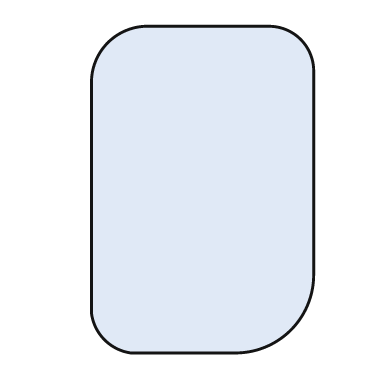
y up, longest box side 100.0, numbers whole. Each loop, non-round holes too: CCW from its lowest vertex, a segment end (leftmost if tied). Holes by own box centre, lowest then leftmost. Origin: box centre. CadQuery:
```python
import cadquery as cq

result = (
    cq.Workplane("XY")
    .moveTo(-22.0, -50.0)
    .lineTo(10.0, -50.0)
    .threePointArc((27.0, -43.0), (34.0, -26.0))
    .lineTo(34.0, 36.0)
    .threePointArc((30.0, 46.0), (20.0, 50.0))
    .lineTo(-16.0, 50.0)
    .threePointArc((-29.0, 45.0), (-34.0, 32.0))
    .lineTo(-34.0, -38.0)
    .threePointArc((-30.0, -46.0), (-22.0, -50.0))
    .close()
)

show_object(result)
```